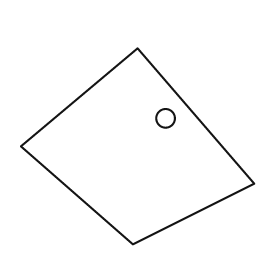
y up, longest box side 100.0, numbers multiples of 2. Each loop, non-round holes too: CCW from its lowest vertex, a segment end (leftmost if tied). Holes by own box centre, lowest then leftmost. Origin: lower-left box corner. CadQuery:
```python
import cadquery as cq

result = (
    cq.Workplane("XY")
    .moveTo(48.0, 0.0)
    .lineTo(100.0, 26.0)
    .lineTo(50.0, 84.0)
    .lineTo(0.0, 42.0)
    .close()
    .moveTo(62.0, 54.0)
    .circle(4.0)
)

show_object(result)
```